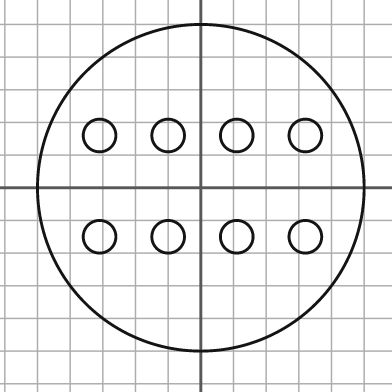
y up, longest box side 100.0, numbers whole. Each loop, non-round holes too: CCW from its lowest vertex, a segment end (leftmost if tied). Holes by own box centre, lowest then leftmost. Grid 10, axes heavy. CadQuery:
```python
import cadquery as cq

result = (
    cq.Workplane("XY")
    .moveTo(0.0, 0.0)
    .circle(50.0)
    .moveTo(-31.0, -15.0)
    .circle(5.0)
    .moveTo(-10.0, -15.0)
    .circle(5.0)
    .moveTo(11.0, -15.0)
    .circle(5.0)
    .moveTo(32.0, -15.0)
    .circle(5.0)
    .moveTo(-31.0, 16.0)
    .circle(5.0)
    .moveTo(-10.0, 16.0)
    .circle(5.0)
    .moveTo(11.0, 16.0)
    .circle(5.0)
    .moveTo(32.0, 16.0)
    .circle(5.0)
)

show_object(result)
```